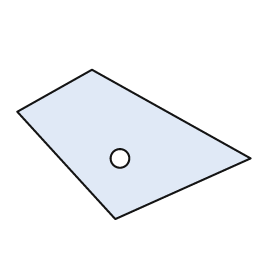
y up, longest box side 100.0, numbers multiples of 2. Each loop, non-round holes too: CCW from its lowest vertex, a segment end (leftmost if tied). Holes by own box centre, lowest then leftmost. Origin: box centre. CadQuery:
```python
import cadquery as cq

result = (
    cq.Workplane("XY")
    .moveTo(-8.0, -32.0)
    .lineTo(50.0, -6.0)
    .lineTo(-18.0, 32.0)
    .lineTo(-50.0, 14.0)
    .close()
    .moveTo(-6.0, -6.0)
    .circle(4.0)
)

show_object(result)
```